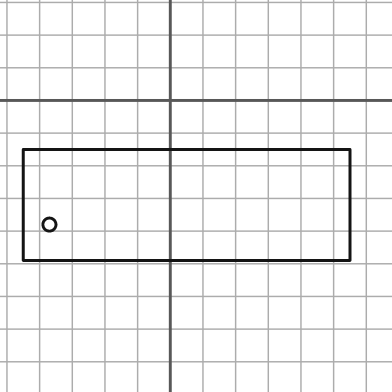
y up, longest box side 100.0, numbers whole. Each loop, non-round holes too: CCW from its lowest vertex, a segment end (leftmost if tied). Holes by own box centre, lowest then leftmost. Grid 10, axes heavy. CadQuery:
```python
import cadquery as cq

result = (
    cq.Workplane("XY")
    .moveTo(-45.0, -49.0)
    .lineTo(55.0, -49.0)
    .lineTo(55.0, -15.0)
    .lineTo(-45.0, -15.0)
    .close()
    .moveTo(-37.0, -38.0)
    .circle(2.0)
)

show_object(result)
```